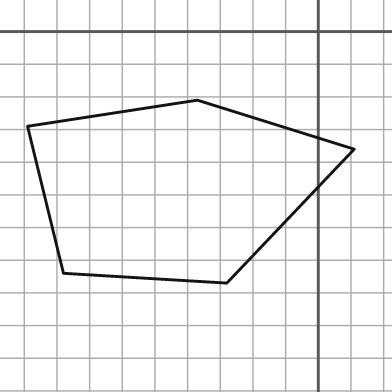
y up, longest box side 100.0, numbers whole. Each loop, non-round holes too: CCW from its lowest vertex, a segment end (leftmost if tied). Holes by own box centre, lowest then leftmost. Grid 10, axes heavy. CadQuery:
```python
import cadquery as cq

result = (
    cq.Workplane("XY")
    .moveTo(-28.0, -77.0)
    .lineTo(11.0, -36.0)
    .lineTo(-37.0, -21.0)
    .lineTo(-89.0, -29.0)
    .lineTo(-78.0, -74.0)
    .close()
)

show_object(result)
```